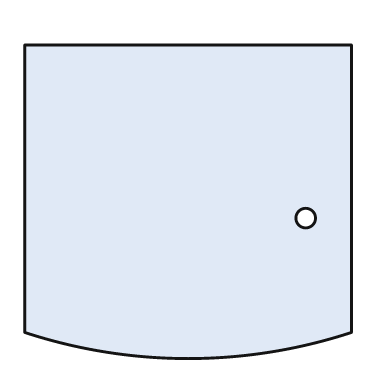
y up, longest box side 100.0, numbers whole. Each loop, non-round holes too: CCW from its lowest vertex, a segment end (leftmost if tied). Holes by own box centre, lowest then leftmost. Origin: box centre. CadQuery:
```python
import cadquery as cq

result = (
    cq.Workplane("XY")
    .moveTo(-50.0, -40.0)
    .threePointArc((0.0, -48.0), (50.0, -40.0))
    .lineTo(50.0, 48.0)
    .lineTo(-50.0, 48.0)
    .close()
    .moveTo(36.0, -5.0)
    .circle(3.0)
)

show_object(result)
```